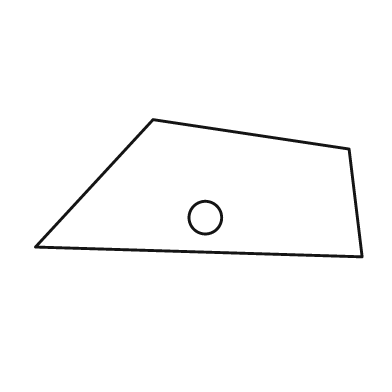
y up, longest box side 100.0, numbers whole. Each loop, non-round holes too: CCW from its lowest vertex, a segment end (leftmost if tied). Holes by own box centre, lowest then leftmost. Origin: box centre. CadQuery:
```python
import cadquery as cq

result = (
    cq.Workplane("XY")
    .moveTo(50.0, -21.0)
    .lineTo(46.0, 12.0)
    .lineTo(-14.0, 21.0)
    .lineTo(-50.0, -18.0)
    .close()
    .moveTo(2.0, -9.0)
    .circle(5.0)
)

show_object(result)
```